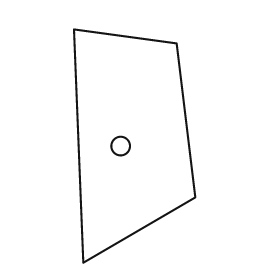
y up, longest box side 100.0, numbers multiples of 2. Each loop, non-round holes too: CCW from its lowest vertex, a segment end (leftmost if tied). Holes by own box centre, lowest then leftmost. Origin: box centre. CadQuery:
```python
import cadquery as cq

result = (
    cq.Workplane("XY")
    .moveTo(-22.0, -50.0)
    .lineTo(26.0, -22.0)
    .lineTo(18.0, 44.0)
    .lineTo(-26.0, 50.0)
    .close()
    .moveTo(-6.0, 0.0)
    .circle(4.0)
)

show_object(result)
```